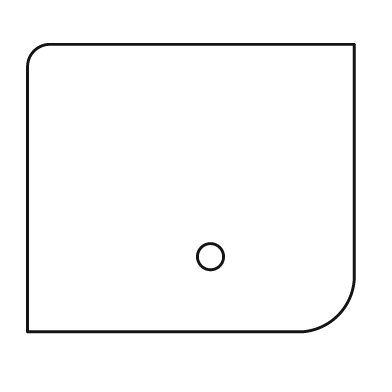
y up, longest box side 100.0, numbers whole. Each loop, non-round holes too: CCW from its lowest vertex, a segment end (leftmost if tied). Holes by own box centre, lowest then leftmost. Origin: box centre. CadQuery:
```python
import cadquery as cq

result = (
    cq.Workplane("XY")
    .moveTo(-50.0, -44.0)
    .lineTo(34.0, -44.0)
    .threePointArc((45.0, -39.0), (50.0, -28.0))
    .lineTo(50.0, 44.0)
    .lineTo(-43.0, 44.0)
    .threePointArc((-48.0, 42.0), (-50.0, 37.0))
    .close()
    .moveTo(6.0, -21.0)
    .circle(4.0)
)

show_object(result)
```